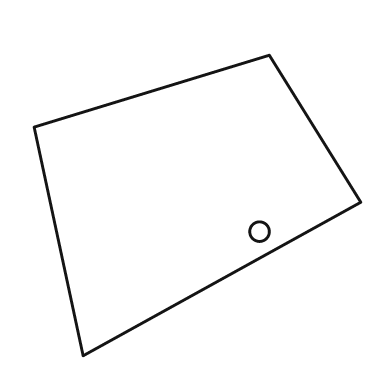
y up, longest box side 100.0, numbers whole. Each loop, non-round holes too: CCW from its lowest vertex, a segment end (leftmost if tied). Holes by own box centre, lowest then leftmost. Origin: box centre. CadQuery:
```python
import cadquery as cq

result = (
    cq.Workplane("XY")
    .moveTo(-35.0, -46.0)
    .lineTo(50.0, 1.0)
    .lineTo(22.0, 46.0)
    .lineTo(-50.0, 24.0)
    .close()
    .moveTo(19.0, -8.0)
    .circle(3.0)
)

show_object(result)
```